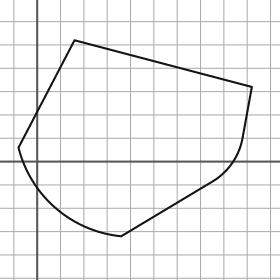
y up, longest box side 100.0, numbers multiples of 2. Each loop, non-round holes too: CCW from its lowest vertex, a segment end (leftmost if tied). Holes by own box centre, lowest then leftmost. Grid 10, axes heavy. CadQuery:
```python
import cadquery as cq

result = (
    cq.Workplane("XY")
    .moveTo(36.0, -32.0)
    .lineTo(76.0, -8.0)
    .threePointArc((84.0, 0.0), (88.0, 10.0))
    .lineTo(92.0, 32.0)
    .lineTo(16.0, 52.0)
    .lineTo(-8.0, 6.0)
    .threePointArc((8.0, -20.0), (36.0, -32.0))
    .close()
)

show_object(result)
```